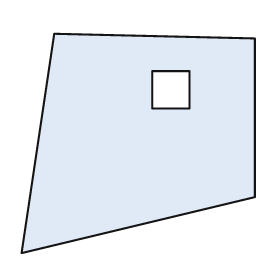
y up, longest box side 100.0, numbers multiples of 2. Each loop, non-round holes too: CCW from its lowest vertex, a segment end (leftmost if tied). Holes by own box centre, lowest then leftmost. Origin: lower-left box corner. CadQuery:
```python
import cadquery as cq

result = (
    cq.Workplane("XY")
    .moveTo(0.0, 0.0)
    .lineTo(100.0, 24.0)
    .lineTo(100.0, 92.0)
    .lineTo(14.0, 94.0)
    .close()
    .moveTo(56.0, 62.0)
    .lineTo(72.0, 62.0)
    .lineTo(72.0, 78.0)
    .lineTo(56.0, 78.0)
    .close()
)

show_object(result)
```